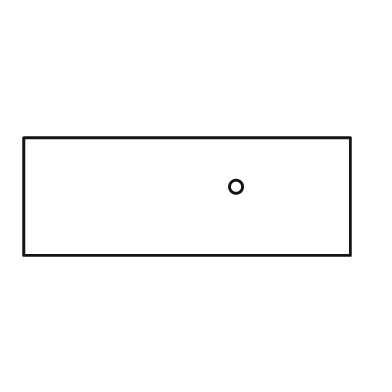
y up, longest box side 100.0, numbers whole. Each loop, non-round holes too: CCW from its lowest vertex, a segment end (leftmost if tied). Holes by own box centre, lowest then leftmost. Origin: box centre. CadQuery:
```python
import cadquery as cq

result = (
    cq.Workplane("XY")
    .moveTo(-50.0, -18.0)
    .lineTo(50.0, -18.0)
    .lineTo(50.0, 18.0)
    .lineTo(-50.0, 18.0)
    .close()
    .moveTo(15.0, 3.0)
    .circle(2.0)
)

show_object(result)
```